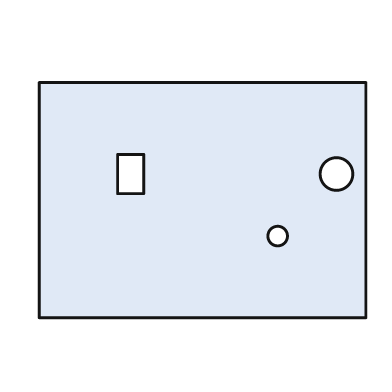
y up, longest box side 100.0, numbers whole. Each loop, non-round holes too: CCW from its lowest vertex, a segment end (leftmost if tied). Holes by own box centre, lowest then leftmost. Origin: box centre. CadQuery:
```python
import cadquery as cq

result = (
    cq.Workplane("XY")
    .moveTo(-50.0, -36.0)
    .lineTo(50.0, -36.0)
    .lineTo(50.0, 36.0)
    .lineTo(-50.0, 36.0)
    .close()
    .moveTo(23.0, -11.0)
    .circle(3.0)
    .moveTo(-26.0, 2.0)
    .lineTo(-18.0, 2.0)
    .lineTo(-18.0, 14.0)
    .lineTo(-26.0, 14.0)
    .close()
    .moveTo(41.0, 8.0)
    .circle(5.0)
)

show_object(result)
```